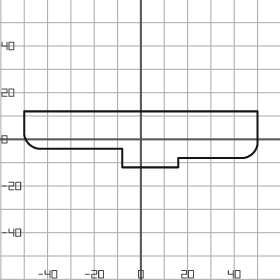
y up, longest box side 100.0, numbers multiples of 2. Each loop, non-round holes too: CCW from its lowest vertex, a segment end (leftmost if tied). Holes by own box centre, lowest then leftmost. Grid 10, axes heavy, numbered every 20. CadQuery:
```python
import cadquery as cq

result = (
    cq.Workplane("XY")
    .moveTo(-8.0, -12.0)
    .lineTo(16.0, -12.0)
    .lineTo(16.0, -8.0)
    .lineTo(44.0, -8.0)
    .threePointArc((48.0, -6.0), (50.0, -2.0))
    .lineTo(50.0, 12.0)
    .lineTo(-50.0, 12.0)
    .lineTo(-50.0, 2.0)
    .threePointArc((-48.0, -2.0), (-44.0, -4.0))
    .lineTo(-8.0, -4.0)
    .close()
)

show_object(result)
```